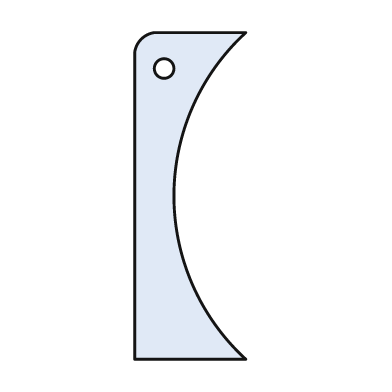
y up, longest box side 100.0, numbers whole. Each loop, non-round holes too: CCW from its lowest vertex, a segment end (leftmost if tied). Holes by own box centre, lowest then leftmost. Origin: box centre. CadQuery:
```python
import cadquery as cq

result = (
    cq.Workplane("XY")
    .moveTo(-17.0, -50.0)
    .lineTo(17.0, -50.0)
    .threePointArc((-5.0, 0.0), (17.0, 50.0))
    .lineTo(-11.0, 50.0)
    .threePointArc((-15.0, 48.0), (-17.0, 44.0))
    .close()
    .moveTo(-8.0, 39.0)
    .circle(3.0)
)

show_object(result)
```